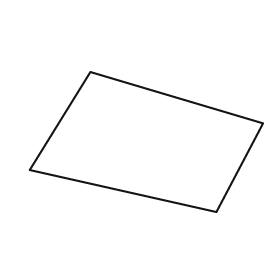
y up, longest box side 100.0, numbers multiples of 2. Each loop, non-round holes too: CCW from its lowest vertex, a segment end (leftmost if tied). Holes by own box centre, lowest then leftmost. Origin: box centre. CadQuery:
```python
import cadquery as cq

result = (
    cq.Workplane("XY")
    .moveTo(30.0, -30.0)
    .lineTo(50.0, 8.0)
    .lineTo(-24.0, 30.0)
    .lineTo(-50.0, -12.0)
    .close()
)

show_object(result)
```